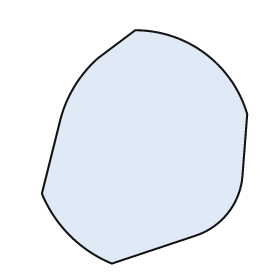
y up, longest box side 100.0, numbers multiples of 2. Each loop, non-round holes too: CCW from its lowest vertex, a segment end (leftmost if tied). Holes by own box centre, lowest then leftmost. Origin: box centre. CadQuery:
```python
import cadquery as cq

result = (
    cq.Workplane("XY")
    .moveTo(-14.0, -50.0)
    .lineTo(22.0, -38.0)
    .threePointArc((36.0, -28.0), (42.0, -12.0))
    .lineTo(44.0, 14.0)
    .threePointArc((26.0, 40.0), (-4.0, 50.0))
    .lineTo(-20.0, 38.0)
    .threePointArc((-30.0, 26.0), (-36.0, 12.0))
    .lineTo(-44.0, -20.0)
    .threePointArc((-32.0, -38.0), (-14.0, -50.0))
    .close()
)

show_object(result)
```